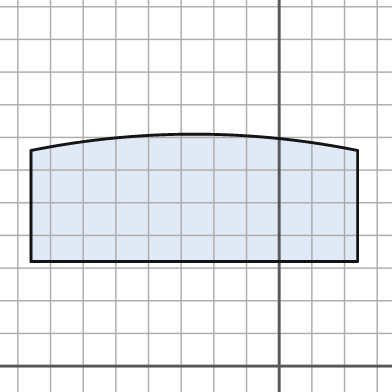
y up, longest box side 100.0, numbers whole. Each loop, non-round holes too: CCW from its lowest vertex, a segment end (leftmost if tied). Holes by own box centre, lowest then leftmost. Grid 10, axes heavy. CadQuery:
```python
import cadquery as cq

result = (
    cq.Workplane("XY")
    .moveTo(-76.0, 32.0)
    .lineTo(24.0, 32.0)
    .lineTo(24.0, 66.0)
    .threePointArc((-26.0, 71.0), (-76.0, 66.0))
    .close()
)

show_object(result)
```